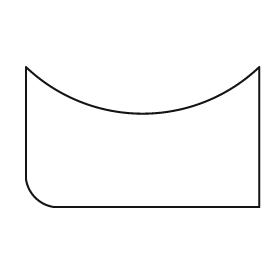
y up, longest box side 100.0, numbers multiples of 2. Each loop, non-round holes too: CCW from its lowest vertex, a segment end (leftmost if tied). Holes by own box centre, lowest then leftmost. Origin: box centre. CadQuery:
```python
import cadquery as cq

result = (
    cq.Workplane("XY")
    .moveTo(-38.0, -30.0)
    .lineTo(50.0, -30.0)
    .lineTo(50.0, 30.0)
    .threePointArc((0.0, 10.0), (-50.0, 30.0))
    .lineTo(-50.0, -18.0)
    .threePointArc((-46.0, -26.0), (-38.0, -30.0))
    .close()
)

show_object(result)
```